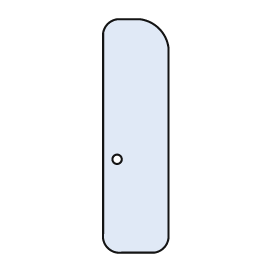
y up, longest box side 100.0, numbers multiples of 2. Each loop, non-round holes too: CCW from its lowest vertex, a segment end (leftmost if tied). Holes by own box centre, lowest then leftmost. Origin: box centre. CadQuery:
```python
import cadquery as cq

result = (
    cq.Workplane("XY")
    .moveTo(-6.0, -50.0)
    .lineTo(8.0, -50.0)
    .threePointArc((12.0, -48.0), (14.0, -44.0))
    .lineTo(14.0, 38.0)
    .threePointArc((10.0, 46.0), (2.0, 50.0))
    .lineTo(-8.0, 50.0)
    .threePointArc((-12.0, 48.0), (-14.0, 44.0))
    .lineTo(-14.0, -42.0)
    .threePointArc((-12.0, -48.0), (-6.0, -50.0))
    .close()
    .moveTo(-8.0, -10.0)
    .circle(2.0)
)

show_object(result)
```